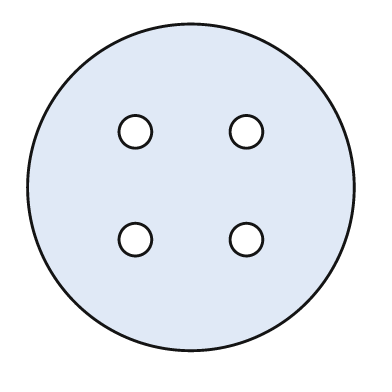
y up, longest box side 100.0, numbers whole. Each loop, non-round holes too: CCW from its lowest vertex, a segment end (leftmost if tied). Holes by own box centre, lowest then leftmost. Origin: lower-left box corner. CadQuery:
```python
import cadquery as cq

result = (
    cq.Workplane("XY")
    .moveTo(50.0, 50.0)
    .circle(50.0)
    .moveTo(33.0, 34.0)
    .circle(5.0)
    .moveTo(67.0, 34.0)
    .circle(5.0)
    .moveTo(33.0, 67.0)
    .circle(5.0)
    .moveTo(67.0, 67.0)
    .circle(5.0)
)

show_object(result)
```